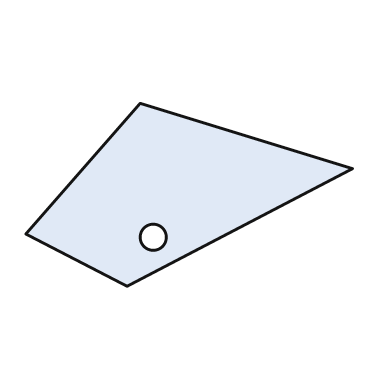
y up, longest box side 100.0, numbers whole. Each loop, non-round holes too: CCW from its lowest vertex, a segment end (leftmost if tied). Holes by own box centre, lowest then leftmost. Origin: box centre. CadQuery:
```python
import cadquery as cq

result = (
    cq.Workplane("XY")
    .moveTo(-19.0, -28.0)
    .lineTo(50.0, 8.0)
    .lineTo(-15.0, 28.0)
    .lineTo(-50.0, -12.0)
    .close()
    .moveTo(-11.0, -13.0)
    .circle(4.0)
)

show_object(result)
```